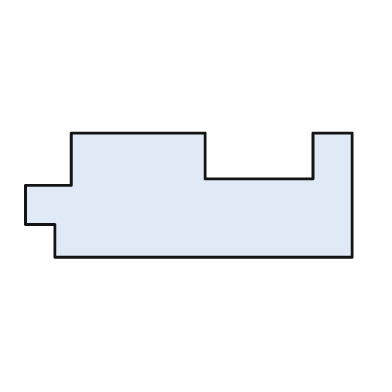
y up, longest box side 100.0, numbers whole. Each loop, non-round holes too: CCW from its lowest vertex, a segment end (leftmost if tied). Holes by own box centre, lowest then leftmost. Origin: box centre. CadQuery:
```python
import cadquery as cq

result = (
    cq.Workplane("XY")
    .moveTo(-41.0, -19.0)
    .lineTo(50.0, -19.0)
    .lineTo(50.0, 19.0)
    .lineTo(38.0, 19.0)
    .lineTo(38.0, 5.0)
    .lineTo(5.0, 5.0)
    .lineTo(5.0, 19.0)
    .lineTo(-36.0, 19.0)
    .lineTo(-36.0, 3.0)
    .lineTo(-50.0, 3.0)
    .lineTo(-50.0, -9.0)
    .lineTo(-41.0, -9.0)
    .close()
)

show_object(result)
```